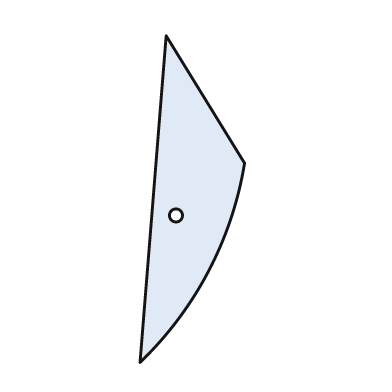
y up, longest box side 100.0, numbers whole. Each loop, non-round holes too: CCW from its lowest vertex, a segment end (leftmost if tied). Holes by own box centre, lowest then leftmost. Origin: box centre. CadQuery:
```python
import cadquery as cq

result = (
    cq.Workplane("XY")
    .moveTo(-16.0, -50.0)
    .threePointArc((5.0, -22.0), (16.0, 11.0))
    .lineTo(-8.0, 50.0)
    .close()
    .moveTo(-5.0, -5.0)
    .circle(2.0)
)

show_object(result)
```